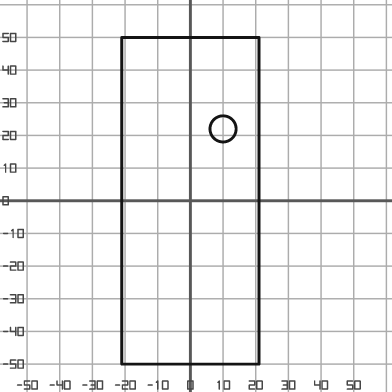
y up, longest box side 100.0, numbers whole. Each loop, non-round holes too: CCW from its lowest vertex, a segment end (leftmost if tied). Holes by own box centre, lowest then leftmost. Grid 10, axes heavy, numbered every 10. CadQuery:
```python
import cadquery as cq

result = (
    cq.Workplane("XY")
    .moveTo(-21.0, -50.0)
    .lineTo(21.0, -50.0)
    .lineTo(21.0, 50.0)
    .lineTo(-21.0, 50.0)
    .close()
    .moveTo(10.0, 22.0)
    .circle(4.0)
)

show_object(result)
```